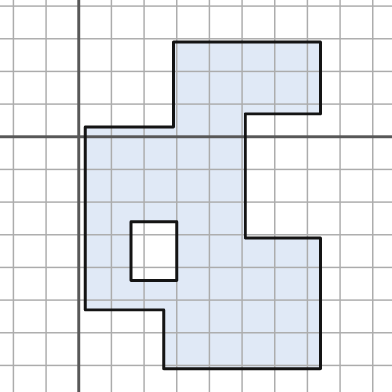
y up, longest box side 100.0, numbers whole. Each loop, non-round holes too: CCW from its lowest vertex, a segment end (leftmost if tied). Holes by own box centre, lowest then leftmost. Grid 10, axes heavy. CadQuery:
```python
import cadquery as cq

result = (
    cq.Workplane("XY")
    .moveTo(26.0, -71.0)
    .lineTo(74.0, -71.0)
    .lineTo(74.0, -31.0)
    .lineTo(51.0, -31.0)
    .lineTo(51.0, 7.0)
    .lineTo(74.0, 7.0)
    .lineTo(74.0, 29.0)
    .lineTo(29.0, 29.0)
    .lineTo(29.0, 3.0)
    .lineTo(2.0, 3.0)
    .lineTo(2.0, -53.0)
    .lineTo(26.0, -53.0)
    .close()
    .moveTo(16.0, -44.0)
    .lineTo(30.0, -44.0)
    .lineTo(30.0, -26.0)
    .lineTo(16.0, -26.0)
    .close()
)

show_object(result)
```